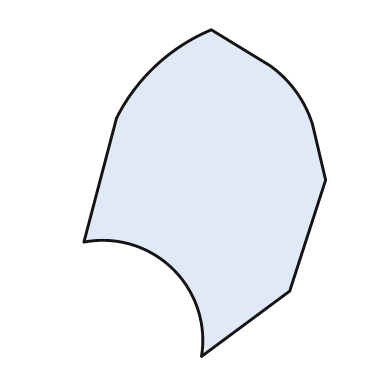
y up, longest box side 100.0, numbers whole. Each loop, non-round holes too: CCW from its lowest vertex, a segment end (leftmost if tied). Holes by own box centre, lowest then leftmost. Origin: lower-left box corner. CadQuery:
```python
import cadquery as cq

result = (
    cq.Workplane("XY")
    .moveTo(36.0, 0.0)
    .lineTo(63.0, 20.0)
    .lineTo(74.0, 54.0)
    .lineTo(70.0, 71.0)
    .threePointArc((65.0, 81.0), (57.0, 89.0))
    .lineTo(39.0, 100.0)
    .threePointArc((22.0, 89.0), (10.0, 73.0))
    .lineTo(0.0, 35.0)
    .threePointArc((27.0, 27.0), (36.0, 0.0))
    .close()
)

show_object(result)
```